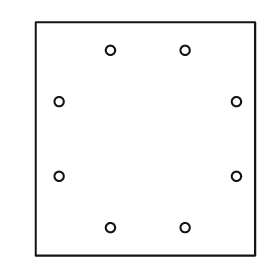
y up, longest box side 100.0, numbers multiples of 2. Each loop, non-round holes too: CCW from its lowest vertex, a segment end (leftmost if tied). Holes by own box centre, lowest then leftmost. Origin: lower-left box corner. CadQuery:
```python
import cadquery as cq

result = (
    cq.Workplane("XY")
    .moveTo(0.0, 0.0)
    .lineTo(94.0, 0.0)
    .lineTo(94.0, 100.0)
    .lineTo(0.0, 100.0)
    .close()
    .moveTo(32.0, 12.0)
    .circle(2.0)
    .moveTo(64.0, 12.0)
    .circle(2.0)
    .moveTo(10.0, 34.0)
    .circle(2.0)
    .moveTo(86.0, 34.0)
    .circle(2.0)
    .moveTo(10.0, 66.0)
    .circle(2.0)
    .moveTo(86.0, 66.0)
    .circle(2.0)
    .moveTo(32.0, 88.0)
    .circle(2.0)
    .moveTo(64.0, 88.0)
    .circle(2.0)
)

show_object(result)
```